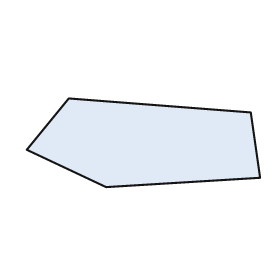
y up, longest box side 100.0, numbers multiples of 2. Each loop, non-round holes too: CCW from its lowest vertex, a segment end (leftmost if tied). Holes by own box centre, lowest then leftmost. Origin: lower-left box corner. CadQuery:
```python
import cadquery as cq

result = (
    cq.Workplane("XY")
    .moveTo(34.0, 0.0)
    .lineTo(100.0, 4.0)
    .lineTo(96.0, 32.0)
    .lineTo(18.0, 38.0)
    .lineTo(0.0, 16.0)
    .close()
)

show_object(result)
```